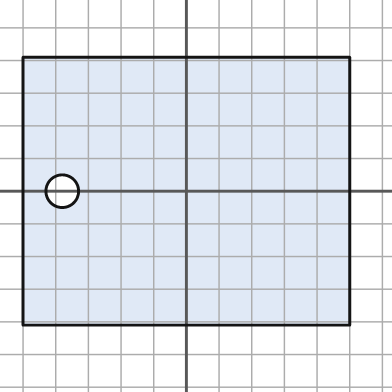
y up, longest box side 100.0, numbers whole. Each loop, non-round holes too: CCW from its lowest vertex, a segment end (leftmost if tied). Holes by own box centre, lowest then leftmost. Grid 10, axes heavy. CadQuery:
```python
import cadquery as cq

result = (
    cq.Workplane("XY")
    .moveTo(-50.0, -41.0)
    .lineTo(50.0, -41.0)
    .lineTo(50.0, 41.0)
    .lineTo(-50.0, 41.0)
    .close()
    .moveTo(-38.0, 0.0)
    .circle(5.0)
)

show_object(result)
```